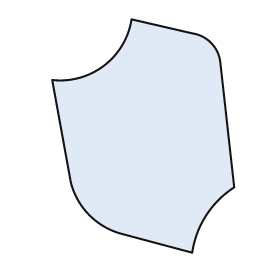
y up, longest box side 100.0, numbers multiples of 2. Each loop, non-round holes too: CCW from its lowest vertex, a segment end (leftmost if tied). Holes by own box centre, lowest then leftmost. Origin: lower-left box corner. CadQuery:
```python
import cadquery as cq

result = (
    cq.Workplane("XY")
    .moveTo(60.0, 0.0)
    .threePointArc((66.0, 16.0), (78.0, 28.0))
    .lineTo(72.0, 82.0)
    .threePointArc((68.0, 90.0), (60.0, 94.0))
    .lineTo(34.0, 100.0)
    .threePointArc((22.0, 80.0), (0.0, 74.0))
    .lineTo(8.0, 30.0)
    .threePointArc((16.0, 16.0), (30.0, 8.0))
    .close()
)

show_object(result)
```